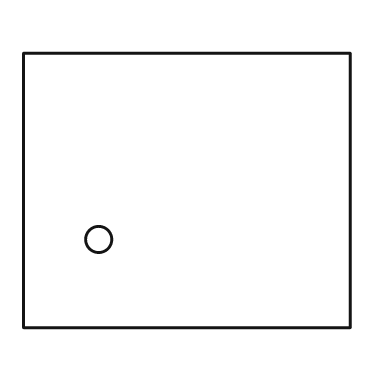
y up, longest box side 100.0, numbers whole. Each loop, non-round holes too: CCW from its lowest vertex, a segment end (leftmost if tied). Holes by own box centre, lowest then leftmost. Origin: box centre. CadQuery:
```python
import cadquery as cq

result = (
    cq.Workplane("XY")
    .moveTo(-50.0, -42.0)
    .lineTo(50.0, -42.0)
    .lineTo(50.0, 42.0)
    .lineTo(-50.0, 42.0)
    .close()
    .moveTo(-27.0, -15.0)
    .circle(4.0)
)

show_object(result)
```